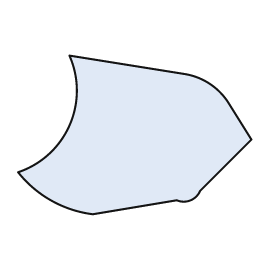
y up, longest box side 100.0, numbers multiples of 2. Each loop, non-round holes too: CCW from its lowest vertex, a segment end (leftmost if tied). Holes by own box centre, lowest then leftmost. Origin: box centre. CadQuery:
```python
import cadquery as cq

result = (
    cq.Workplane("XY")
    .moveTo(-18.0, -34.0)
    .lineTo(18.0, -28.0)
    .threePointArc((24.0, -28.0), (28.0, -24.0))
    .lineTo(50.0, -2.0)
    .lineTo(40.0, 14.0)
    .threePointArc((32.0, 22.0), (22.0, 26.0))
    .lineTo(-28.0, 34.0)
    .threePointArc((-28.0, 4.0), (-50.0, -16.0))
    .threePointArc((-36.0, -28.0), (-18.0, -34.0))
    .close()
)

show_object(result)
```